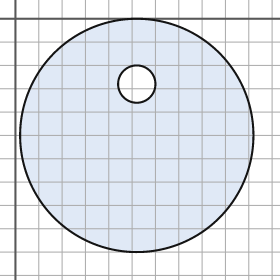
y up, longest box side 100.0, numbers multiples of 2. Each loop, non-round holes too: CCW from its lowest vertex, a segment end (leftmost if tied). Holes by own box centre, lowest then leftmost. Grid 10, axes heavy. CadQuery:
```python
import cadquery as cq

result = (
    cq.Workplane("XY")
    .moveTo(52.0, -50.0)
    .circle(50.0)
    .moveTo(52.0, -28.0)
    .circle(8.0)
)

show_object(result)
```